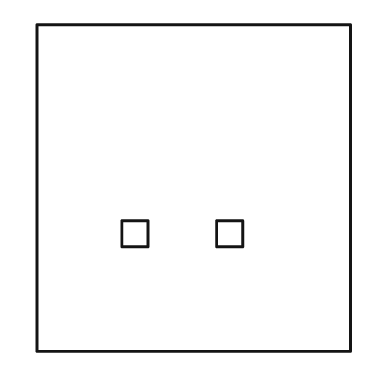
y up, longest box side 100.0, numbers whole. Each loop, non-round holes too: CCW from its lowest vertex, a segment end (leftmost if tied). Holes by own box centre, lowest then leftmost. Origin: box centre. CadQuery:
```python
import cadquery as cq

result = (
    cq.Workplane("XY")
    .moveTo(-48.0, -50.0)
    .lineTo(48.0, -50.0)
    .lineTo(48.0, 50.0)
    .lineTo(-48.0, 50.0)
    .close()
    .moveTo(-22.0, -18.0)
    .lineTo(-14.0, -18.0)
    .lineTo(-14.0, -10.0)
    .lineTo(-22.0, -10.0)
    .close()
    .moveTo(7.0, -18.0)
    .lineTo(15.0, -18.0)
    .lineTo(15.0, -10.0)
    .lineTo(7.0, -10.0)
    .close()
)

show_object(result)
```